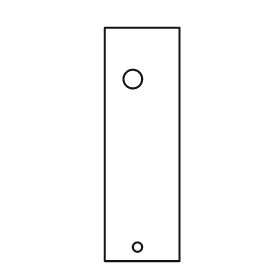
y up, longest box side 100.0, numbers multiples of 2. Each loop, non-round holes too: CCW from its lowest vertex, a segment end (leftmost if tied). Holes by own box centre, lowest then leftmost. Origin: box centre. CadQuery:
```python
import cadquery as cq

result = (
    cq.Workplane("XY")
    .moveTo(-16.0, -50.0)
    .lineTo(16.0, -50.0)
    .lineTo(16.0, 50.0)
    .lineTo(-16.0, 50.0)
    .close()
    .moveTo(-2.0, -44.0)
    .circle(2.0)
    .moveTo(-4.0, 28.0)
    .circle(4.0)
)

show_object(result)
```